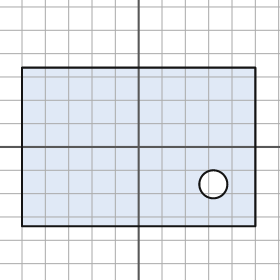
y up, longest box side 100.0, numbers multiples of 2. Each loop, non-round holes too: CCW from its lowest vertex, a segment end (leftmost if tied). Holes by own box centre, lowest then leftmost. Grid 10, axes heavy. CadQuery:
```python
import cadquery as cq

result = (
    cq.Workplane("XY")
    .moveTo(-50.0, -34.0)
    .lineTo(50.0, -34.0)
    .lineTo(50.0, 34.0)
    .lineTo(-50.0, 34.0)
    .close()
    .moveTo(32.0, -16.0)
    .circle(6.0)
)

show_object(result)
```